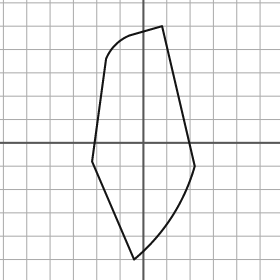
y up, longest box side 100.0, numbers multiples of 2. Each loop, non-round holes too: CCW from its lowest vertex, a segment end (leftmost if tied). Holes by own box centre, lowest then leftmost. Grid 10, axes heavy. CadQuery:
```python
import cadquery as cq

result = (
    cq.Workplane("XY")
    .moveTo(-4.0, -50.0)
    .threePointArc((12.0, -32.0), (22.0, -10.0))
    .lineTo(8.0, 50.0)
    .lineTo(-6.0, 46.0)
    .threePointArc((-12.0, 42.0), (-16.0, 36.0))
    .lineTo(-22.0, -8.0)
    .close()
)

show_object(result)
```